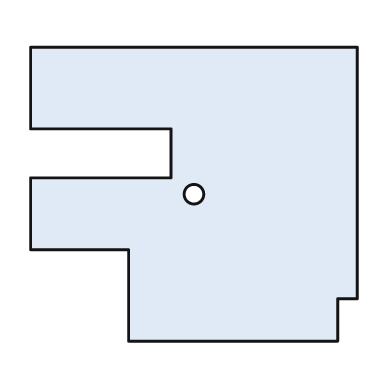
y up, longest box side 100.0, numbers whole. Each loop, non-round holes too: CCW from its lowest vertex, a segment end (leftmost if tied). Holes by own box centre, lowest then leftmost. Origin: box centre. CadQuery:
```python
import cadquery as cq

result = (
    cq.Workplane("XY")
    .moveTo(-20.0, -45.0)
    .lineTo(44.0, -45.0)
    .lineTo(44.0, -32.0)
    .lineTo(50.0, -32.0)
    .lineTo(50.0, 45.0)
    .lineTo(-50.0, 45.0)
    .lineTo(-50.0, 20.0)
    .lineTo(-7.0, 20.0)
    .lineTo(-7.0, 5.0)
    .lineTo(-50.0, 5.0)
    .lineTo(-50.0, -17.0)
    .lineTo(-20.0, -17.0)
    .close()
    .moveTo(0.0, 0.0)
    .circle(3.0)
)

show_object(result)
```